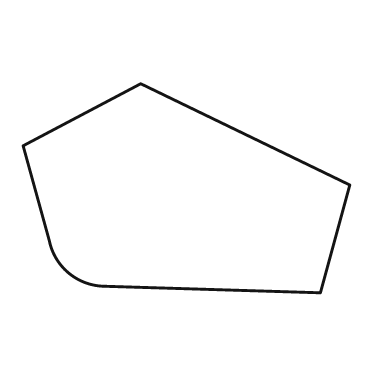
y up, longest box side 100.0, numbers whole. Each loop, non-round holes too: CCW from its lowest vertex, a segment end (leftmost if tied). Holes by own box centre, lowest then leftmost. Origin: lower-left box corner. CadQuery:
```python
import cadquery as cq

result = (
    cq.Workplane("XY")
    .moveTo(91.0, 0.0)
    .lineTo(100.0, 33.0)
    .lineTo(36.0, 64.0)
    .lineTo(0.0, 45.0)
    .lineTo(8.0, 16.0)
    .threePointArc((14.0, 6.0), (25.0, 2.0))
    .close()
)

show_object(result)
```